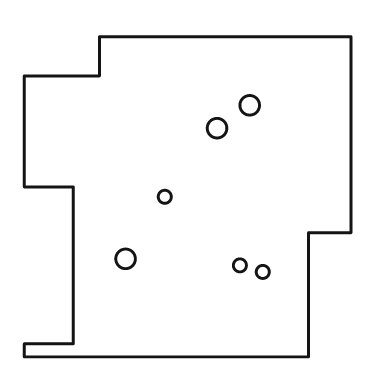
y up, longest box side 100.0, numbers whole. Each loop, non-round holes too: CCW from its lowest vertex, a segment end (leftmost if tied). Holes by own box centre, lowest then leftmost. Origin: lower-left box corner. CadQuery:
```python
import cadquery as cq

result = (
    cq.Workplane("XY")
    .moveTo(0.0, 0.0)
    .lineTo(87.0, 0.0)
    .lineTo(87.0, 38.0)
    .lineTo(100.0, 38.0)
    .lineTo(100.0, 98.0)
    .lineTo(23.0, 98.0)
    .lineTo(23.0, 86.0)
    .lineTo(0.0, 86.0)
    .lineTo(0.0, 52.0)
    .lineTo(15.0, 52.0)
    .lineTo(15.0, 4.0)
    .lineTo(0.0, 4.0)
    .close()
    .moveTo(73.0, 26.0)
    .circle(2.0)
    .moveTo(66.0, 28.0)
    .circle(2.0)
    .moveTo(31.0, 30.0)
    .circle(3.0)
    .moveTo(43.0, 49.0)
    .circle(2.0)
    .moveTo(59.0, 70.0)
    .circle(3.0)
    .moveTo(69.0, 77.0)
    .circle(3.0)
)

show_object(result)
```